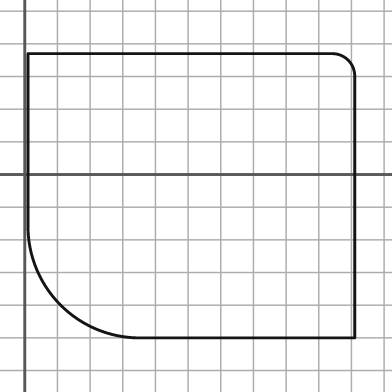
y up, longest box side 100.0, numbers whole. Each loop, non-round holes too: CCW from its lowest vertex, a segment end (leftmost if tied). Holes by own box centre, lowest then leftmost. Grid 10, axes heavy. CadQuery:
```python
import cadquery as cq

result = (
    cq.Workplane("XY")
    .moveTo(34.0, -50.0)
    .lineTo(101.0, -50.0)
    .lineTo(101.0, 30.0)
    .threePointArc((99.0, 35.0), (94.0, 37.0))
    .lineTo(1.0, 37.0)
    .lineTo(1.0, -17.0)
    .threePointArc((11.0, -40.0), (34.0, -50.0))
    .close()
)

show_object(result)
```